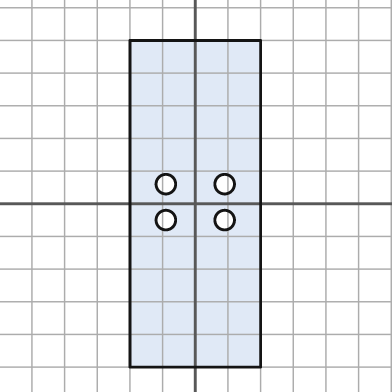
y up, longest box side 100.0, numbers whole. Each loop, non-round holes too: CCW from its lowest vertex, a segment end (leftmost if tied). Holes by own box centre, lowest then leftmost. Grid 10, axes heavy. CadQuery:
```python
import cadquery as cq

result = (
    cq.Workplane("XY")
    .moveTo(-20.0, -50.0)
    .lineTo(20.0, -50.0)
    .lineTo(20.0, 50.0)
    .lineTo(-20.0, 50.0)
    .close()
    .moveTo(-9.0, -5.0)
    .circle(3.0)
    .moveTo(9.0, -5.0)
    .circle(3.0)
    .moveTo(-9.0, 6.0)
    .circle(3.0)
    .moveTo(9.0, 6.0)
    .circle(3.0)
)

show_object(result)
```